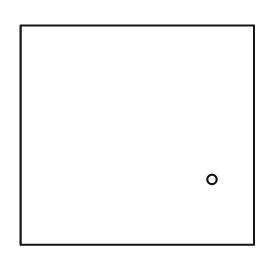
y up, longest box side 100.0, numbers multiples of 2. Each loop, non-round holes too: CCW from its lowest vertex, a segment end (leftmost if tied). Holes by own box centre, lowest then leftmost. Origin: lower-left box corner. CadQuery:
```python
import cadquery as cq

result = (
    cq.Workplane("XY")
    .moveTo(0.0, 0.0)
    .lineTo(100.0, 0.0)
    .lineTo(100.0, 94.0)
    .lineTo(0.0, 94.0)
    .close()
    .moveTo(82.0, 28.0)
    .circle(2.0)
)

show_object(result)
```